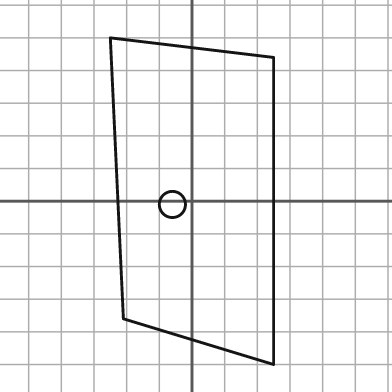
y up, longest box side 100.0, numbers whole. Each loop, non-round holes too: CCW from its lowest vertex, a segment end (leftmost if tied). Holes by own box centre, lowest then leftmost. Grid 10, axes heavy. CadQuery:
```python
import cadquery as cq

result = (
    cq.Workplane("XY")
    .moveTo(25.0, -50.0)
    .lineTo(25.0, 44.0)
    .lineTo(-25.0, 50.0)
    .lineTo(-21.0, -36.0)
    .close()
    .moveTo(-6.0, -1.0)
    .circle(4.0)
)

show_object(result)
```